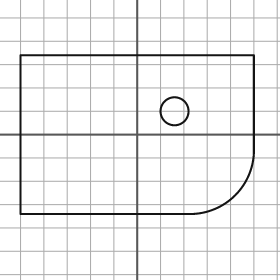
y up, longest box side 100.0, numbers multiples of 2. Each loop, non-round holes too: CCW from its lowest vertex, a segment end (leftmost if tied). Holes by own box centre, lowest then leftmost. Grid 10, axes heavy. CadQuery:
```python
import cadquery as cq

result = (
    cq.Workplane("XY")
    .moveTo(-50.0, -34.0)
    .lineTo(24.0, -34.0)
    .threePointArc((42.0, -26.0), (50.0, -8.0))
    .lineTo(50.0, 34.0)
    .lineTo(-50.0, 34.0)
    .close()
    .moveTo(16.0, 10.0)
    .circle(6.0)
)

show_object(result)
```